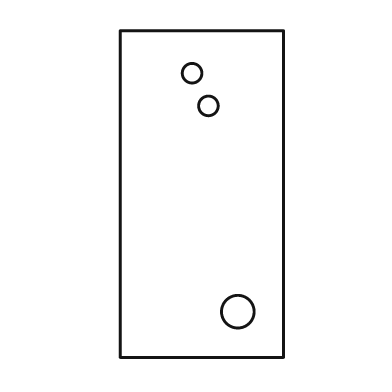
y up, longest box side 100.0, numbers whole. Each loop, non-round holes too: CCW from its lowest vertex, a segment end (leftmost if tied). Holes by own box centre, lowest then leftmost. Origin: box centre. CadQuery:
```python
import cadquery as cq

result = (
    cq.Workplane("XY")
    .moveTo(-25.0, -50.0)
    .lineTo(25.0, -50.0)
    .lineTo(25.0, 50.0)
    .lineTo(-25.0, 50.0)
    .close()
    .moveTo(11.0, -36.0)
    .circle(5.0)
    .moveTo(2.0, 27.0)
    .circle(3.0)
    .moveTo(-3.0, 37.0)
    .circle(3.0)
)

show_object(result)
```